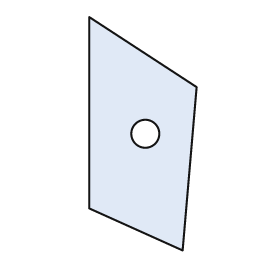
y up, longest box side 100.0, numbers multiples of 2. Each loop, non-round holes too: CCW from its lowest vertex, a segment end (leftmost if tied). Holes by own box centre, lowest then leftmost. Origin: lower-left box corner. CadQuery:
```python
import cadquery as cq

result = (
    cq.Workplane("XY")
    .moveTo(40.0, 0.0)
    .lineTo(46.0, 70.0)
    .lineTo(0.0, 100.0)
    .lineTo(0.0, 18.0)
    .close()
    .moveTo(24.0, 50.0)
    .circle(6.0)
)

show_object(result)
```